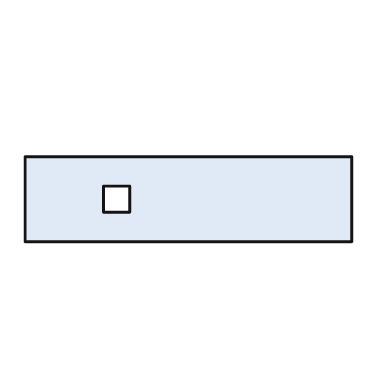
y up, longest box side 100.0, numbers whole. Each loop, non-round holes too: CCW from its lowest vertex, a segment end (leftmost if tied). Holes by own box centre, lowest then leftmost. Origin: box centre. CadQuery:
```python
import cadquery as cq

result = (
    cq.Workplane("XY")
    .moveTo(-50.0, -13.0)
    .lineTo(50.0, -13.0)
    .lineTo(50.0, 13.0)
    .lineTo(-50.0, 13.0)
    .close()
    .moveTo(-26.0, -4.0)
    .lineTo(-18.0, -4.0)
    .lineTo(-18.0, 4.0)
    .lineTo(-26.0, 4.0)
    .close()
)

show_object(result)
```